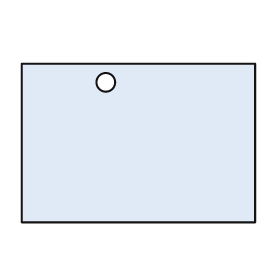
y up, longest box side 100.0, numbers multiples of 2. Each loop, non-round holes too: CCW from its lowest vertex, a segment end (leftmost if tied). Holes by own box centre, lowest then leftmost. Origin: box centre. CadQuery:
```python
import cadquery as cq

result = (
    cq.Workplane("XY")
    .moveTo(-50.0, -34.0)
    .lineTo(50.0, -34.0)
    .lineTo(50.0, 34.0)
    .lineTo(-50.0, 34.0)
    .close()
    .moveTo(-14.0, 26.0)
    .circle(4.0)
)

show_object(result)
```